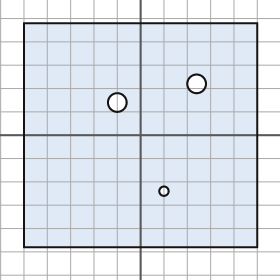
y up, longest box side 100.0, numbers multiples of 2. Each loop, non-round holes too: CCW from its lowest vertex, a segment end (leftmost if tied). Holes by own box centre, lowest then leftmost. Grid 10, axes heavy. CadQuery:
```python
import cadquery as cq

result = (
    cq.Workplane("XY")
    .moveTo(-50.0, -48.0)
    .lineTo(50.0, -48.0)
    .lineTo(50.0, 48.0)
    .lineTo(-50.0, 48.0)
    .close()
    .moveTo(10.0, -24.0)
    .circle(2.0)
    .moveTo(-10.0, 14.0)
    .circle(4.0)
    .moveTo(24.0, 22.0)
    .circle(4.0)
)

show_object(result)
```